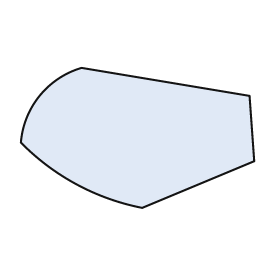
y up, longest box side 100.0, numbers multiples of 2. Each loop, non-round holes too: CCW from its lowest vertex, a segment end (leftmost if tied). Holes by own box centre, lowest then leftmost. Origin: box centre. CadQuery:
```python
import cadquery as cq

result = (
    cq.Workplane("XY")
    .moveTo(2.0, -30.0)
    .lineTo(50.0, -10.0)
    .lineTo(48.0, 18.0)
    .lineTo(-24.0, 30.0)
    .threePointArc((-42.0, 18.0), (-50.0, -2.0))
    .threePointArc((-26.0, -20.0), (2.0, -30.0))
    .close()
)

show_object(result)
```